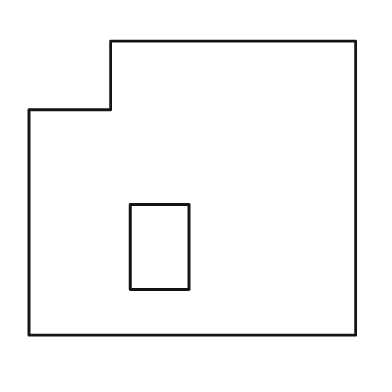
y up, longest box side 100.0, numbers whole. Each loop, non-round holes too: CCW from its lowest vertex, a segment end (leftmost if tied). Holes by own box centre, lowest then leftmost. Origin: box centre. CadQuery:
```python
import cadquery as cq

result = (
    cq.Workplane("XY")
    .moveTo(-50.0, -45.0)
    .lineTo(50.0, -45.0)
    .lineTo(50.0, 45.0)
    .lineTo(-25.0, 45.0)
    .lineTo(-25.0, 24.0)
    .lineTo(-50.0, 24.0)
    .close()
    .moveTo(-19.0, -31.0)
    .lineTo(-1.0, -31.0)
    .lineTo(-1.0, -5.0)
    .lineTo(-19.0, -5.0)
    .close()
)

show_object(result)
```